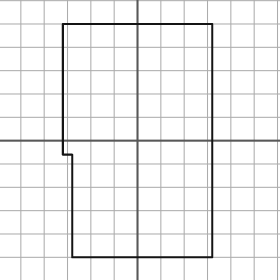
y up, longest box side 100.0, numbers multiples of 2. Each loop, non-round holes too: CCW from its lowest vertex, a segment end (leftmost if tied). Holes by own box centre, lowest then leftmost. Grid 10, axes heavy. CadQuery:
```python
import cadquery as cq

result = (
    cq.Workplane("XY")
    .moveTo(-28.0, -50.0)
    .lineTo(32.0, -50.0)
    .lineTo(32.0, 50.0)
    .lineTo(-32.0, 50.0)
    .lineTo(-32.0, -6.0)
    .lineTo(-28.0, -6.0)
    .close()
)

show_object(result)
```